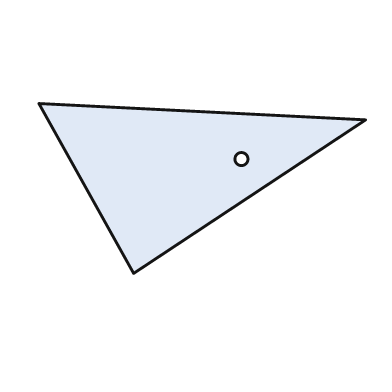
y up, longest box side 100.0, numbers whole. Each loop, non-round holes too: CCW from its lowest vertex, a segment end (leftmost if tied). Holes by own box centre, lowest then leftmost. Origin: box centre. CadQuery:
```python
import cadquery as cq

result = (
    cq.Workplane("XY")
    .moveTo(-21.0, -26.0)
    .lineTo(50.0, 21.0)
    .lineTo(-50.0, 26.0)
    .close()
    .moveTo(12.0, 9.0)
    .circle(2.0)
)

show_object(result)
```